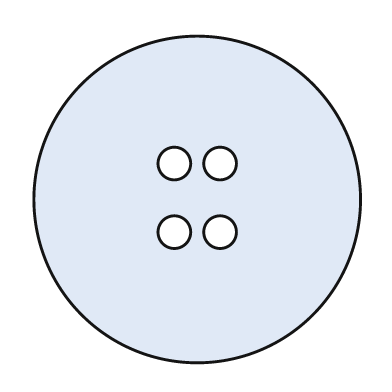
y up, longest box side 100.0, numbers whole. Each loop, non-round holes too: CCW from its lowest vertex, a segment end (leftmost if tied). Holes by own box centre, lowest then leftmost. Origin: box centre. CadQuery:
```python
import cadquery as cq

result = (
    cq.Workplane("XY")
    .moveTo(0.0, 0.0)
    .circle(50.0)
    .moveTo(-7.0, -10.0)
    .circle(5.0)
    .moveTo(7.0, -10.0)
    .circle(5.0)
    .moveTo(-7.0, 11.0)
    .circle(5.0)
    .moveTo(7.0, 11.0)
    .circle(5.0)
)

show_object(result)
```